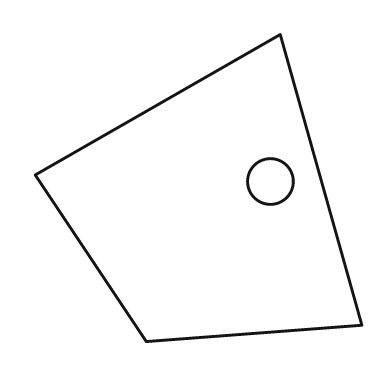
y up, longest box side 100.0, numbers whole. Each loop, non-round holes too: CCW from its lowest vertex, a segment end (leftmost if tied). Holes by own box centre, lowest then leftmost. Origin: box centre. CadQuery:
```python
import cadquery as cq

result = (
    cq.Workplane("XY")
    .moveTo(-16.0, -47.0)
    .lineTo(50.0, -42.0)
    .lineTo(25.0, 47.0)
    .lineTo(-50.0, 4.0)
    .close()
    .moveTo(22.0, 2.0)
    .circle(7.0)
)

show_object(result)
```